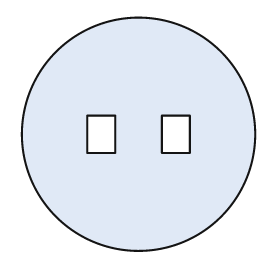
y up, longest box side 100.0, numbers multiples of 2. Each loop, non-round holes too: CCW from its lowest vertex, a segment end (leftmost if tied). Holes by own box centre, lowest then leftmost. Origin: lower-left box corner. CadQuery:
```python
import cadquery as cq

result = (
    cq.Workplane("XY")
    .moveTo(50.0, 50.0)
    .circle(50.0)
    .moveTo(28.0, 42.0)
    .lineTo(40.0, 42.0)
    .lineTo(40.0, 58.0)
    .lineTo(28.0, 58.0)
    .close()
    .moveTo(60.0, 42.0)
    .lineTo(72.0, 42.0)
    .lineTo(72.0, 58.0)
    .lineTo(60.0, 58.0)
    .close()
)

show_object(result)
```